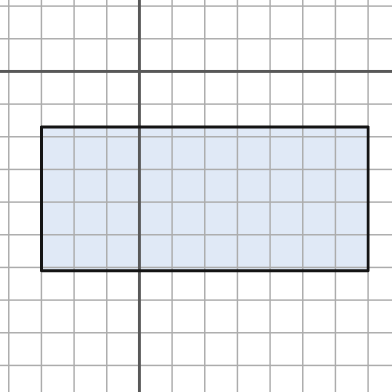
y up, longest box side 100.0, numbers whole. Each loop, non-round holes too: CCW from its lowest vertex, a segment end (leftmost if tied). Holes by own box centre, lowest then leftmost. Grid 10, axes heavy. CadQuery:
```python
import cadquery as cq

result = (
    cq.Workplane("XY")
    .moveTo(-30.0, -61.0)
    .lineTo(70.0, -61.0)
    .lineTo(70.0, -17.0)
    .lineTo(-30.0, -17.0)
    .close()
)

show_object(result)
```